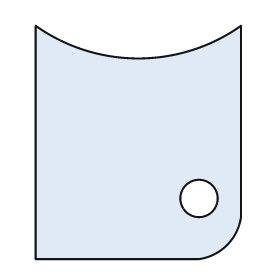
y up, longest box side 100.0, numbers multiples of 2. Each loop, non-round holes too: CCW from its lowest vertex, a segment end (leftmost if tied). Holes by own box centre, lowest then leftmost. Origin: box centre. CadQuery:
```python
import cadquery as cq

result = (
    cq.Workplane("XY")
    .moveTo(-44.0, -50.0)
    .lineTo(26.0, -50.0)
    .threePointArc((38.0, -44.0), (44.0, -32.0))
    .lineTo(44.0, 50.0)
    .threePointArc((0.0, 36.0), (-44.0, 50.0))
    .close()
    .moveTo(26.0, -24.0)
    .circle(8.0)
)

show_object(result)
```